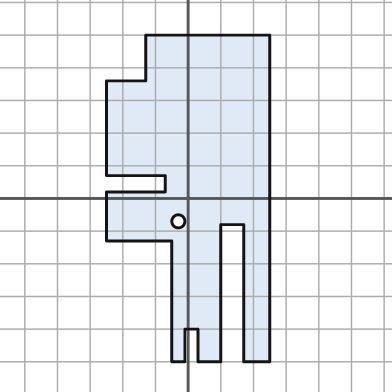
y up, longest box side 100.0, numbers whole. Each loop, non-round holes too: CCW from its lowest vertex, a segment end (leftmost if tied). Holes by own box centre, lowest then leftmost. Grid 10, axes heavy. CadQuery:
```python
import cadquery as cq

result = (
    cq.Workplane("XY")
    .moveTo(-5.0, -50.0)
    .lineTo(-1.0, -50.0)
    .lineTo(-1.0, -40.0)
    .lineTo(3.0, -40.0)
    .lineTo(3.0, -50.0)
    .lineTo(10.0, -50.0)
    .lineTo(10.0, -8.0)
    .lineTo(17.0, -8.0)
    .lineTo(17.0, -50.0)
    .lineTo(25.0, -50.0)
    .lineTo(25.0, 50.0)
    .lineTo(-13.0, 50.0)
    .lineTo(-13.0, 36.0)
    .lineTo(-25.0, 36.0)
    .lineTo(-25.0, 7.0)
    .lineTo(-7.0, 7.0)
    .lineTo(-7.0, 2.0)
    .lineTo(-25.0, 2.0)
    .lineTo(-25.0, -13.0)
    .lineTo(-5.0, -13.0)
    .close()
    .moveTo(-3.0, -7.0)
    .circle(2.0)
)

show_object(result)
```